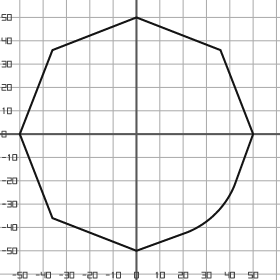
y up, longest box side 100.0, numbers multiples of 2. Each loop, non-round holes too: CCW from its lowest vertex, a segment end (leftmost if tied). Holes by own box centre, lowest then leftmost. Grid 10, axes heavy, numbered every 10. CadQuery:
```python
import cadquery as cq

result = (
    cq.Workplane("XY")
    .moveTo(0.0, -50.0)
    .lineTo(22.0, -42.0)
    .threePointArc((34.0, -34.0), (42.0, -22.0))
    .lineTo(50.0, 0.0)
    .lineTo(36.0, 36.0)
    .lineTo(0.0, 50.0)
    .lineTo(-36.0, 36.0)
    .lineTo(-50.0, 0.0)
    .lineTo(-36.0, -36.0)
    .close()
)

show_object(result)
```